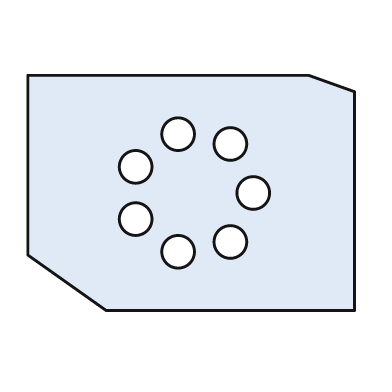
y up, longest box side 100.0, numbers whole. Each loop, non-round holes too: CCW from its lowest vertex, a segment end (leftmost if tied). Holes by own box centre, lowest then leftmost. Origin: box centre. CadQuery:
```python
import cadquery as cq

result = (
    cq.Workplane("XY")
    .moveTo(-26.0, -36.0)
    .lineTo(50.0, -36.0)
    .lineTo(50.0, 31.0)
    .lineTo(36.0, 36.0)
    .lineTo(-50.0, 36.0)
    .lineTo(-50.0, -19.0)
    .close()
    .moveTo(-4.0, -18.0)
    .circle(5.0)
    .moveTo(12.0, -15.0)
    .circle(5.0)
    .moveTo(-17.0, -8.0)
    .circle(5.0)
    .moveTo(19.0, 0.0)
    .circle(5.0)
    .moveTo(-17.0, 8.0)
    .circle(5.0)
    .moveTo(12.0, 15.0)
    .circle(5.0)
    .moveTo(-4.0, 18.0)
    .circle(5.0)
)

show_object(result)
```